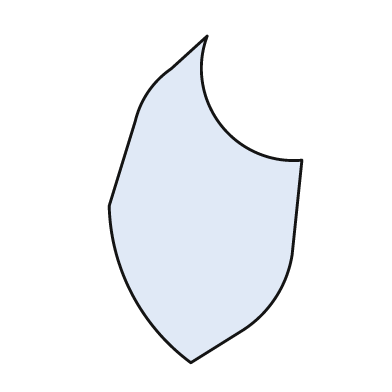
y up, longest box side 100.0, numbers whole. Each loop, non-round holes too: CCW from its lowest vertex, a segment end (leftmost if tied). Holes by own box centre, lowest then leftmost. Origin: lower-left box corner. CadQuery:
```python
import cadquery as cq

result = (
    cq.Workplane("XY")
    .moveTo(25.0, 0.0)
    .lineTo(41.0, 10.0)
    .threePointArc((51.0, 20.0), (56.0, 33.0))
    .lineTo(59.0, 62.0)
    .threePointArc((34.0, 73.0), (30.0, 100.0))
    .lineTo(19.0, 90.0)
    .threePointArc((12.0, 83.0), (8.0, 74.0))
    .lineTo(0.0, 48.0)
    .threePointArc((7.0, 21.0), (25.0, 0.0))
    .close()
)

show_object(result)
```